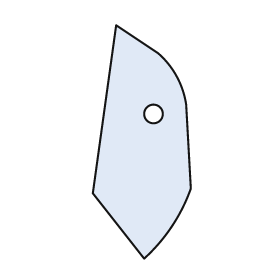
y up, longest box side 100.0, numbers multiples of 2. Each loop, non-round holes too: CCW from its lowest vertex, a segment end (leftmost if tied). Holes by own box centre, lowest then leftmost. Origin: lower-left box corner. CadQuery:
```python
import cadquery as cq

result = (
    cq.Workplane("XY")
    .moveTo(22.0, 0.0)
    .threePointArc((34.0, 14.0), (42.0, 30.0))
    .lineTo(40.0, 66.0)
    .threePointArc((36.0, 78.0), (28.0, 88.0))
    .lineTo(10.0, 100.0)
    .lineTo(0.0, 28.0)
    .close()
    .moveTo(26.0, 62.0)
    .circle(4.0)
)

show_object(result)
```